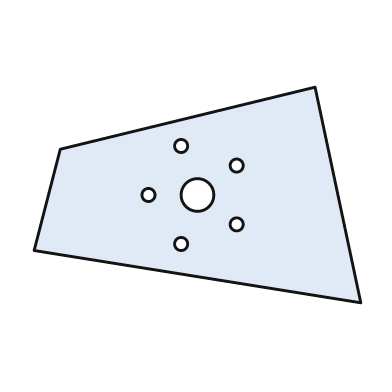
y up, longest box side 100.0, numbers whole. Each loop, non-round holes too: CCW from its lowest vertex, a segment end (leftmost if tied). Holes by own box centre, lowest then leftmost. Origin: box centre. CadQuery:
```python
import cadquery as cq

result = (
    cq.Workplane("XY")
    .moveTo(50.0, -33.0)
    .lineTo(36.0, 33.0)
    .lineTo(-42.0, 14.0)
    .lineTo(-50.0, -17.0)
    .close()
    .moveTo(-5.0, -15.0)
    .circle(2.0)
    .moveTo(12.0, -9.0)
    .circle(2.0)
    .moveTo(-15.0, 0.0)
    .circle(2.0)
    .moveTo(0.0, 0.0)
    .circle(5.0)
    .moveTo(12.0, 9.0)
    .circle(2.0)
    .moveTo(-5.0, 15.0)
    .circle(2.0)
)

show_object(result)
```